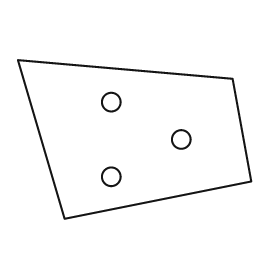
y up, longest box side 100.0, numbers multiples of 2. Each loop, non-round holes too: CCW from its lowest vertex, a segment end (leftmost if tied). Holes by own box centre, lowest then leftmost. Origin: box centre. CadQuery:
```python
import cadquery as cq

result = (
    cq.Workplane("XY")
    .moveTo(-30.0, -34.0)
    .lineTo(50.0, -18.0)
    .lineTo(42.0, 26.0)
    .lineTo(-50.0, 34.0)
    .close()
    .moveTo(-10.0, -16.0)
    .circle(4.0)
    .moveTo(20.0, 0.0)
    .circle(4.0)
    .moveTo(-10.0, 16.0)
    .circle(4.0)
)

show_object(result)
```